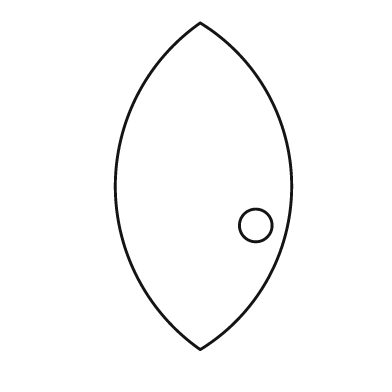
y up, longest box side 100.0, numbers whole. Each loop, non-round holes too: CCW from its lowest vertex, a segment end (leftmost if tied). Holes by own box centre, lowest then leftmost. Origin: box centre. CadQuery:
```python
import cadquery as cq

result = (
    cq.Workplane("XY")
    .moveTo(-1.0, -50.0)
    .threePointArc((27.0, 0.0), (-1.0, 50.0))
    .threePointArc((-27.0, 0.0), (-1.0, -50.0))
    .close()
    .moveTo(16.0, -12.0)
    .circle(5.0)
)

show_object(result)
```